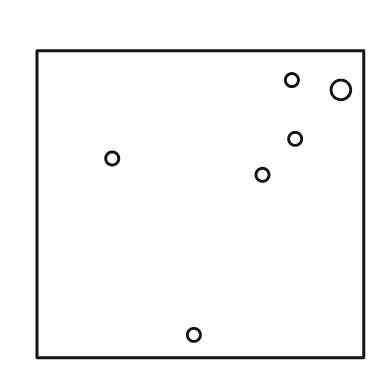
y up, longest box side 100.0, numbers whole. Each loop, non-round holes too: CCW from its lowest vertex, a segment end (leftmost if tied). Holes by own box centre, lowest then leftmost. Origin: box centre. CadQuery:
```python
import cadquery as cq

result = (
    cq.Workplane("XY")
    .moveTo(-50.0, -47.0)
    .lineTo(50.0, -47.0)
    .lineTo(50.0, 47.0)
    .lineTo(-50.0, 47.0)
    .close()
    .moveTo(-2.0, -40.0)
    .circle(2.0)
    .moveTo(19.0, 9.0)
    .circle(2.0)
    .moveTo(-27.0, 14.0)
    .circle(2.0)
    .moveTo(29.0, 20.0)
    .circle(2.0)
    .moveTo(43.0, 35.0)
    .circle(3.0)
    .moveTo(28.0, 38.0)
    .circle(2.0)
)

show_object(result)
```